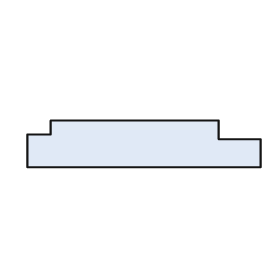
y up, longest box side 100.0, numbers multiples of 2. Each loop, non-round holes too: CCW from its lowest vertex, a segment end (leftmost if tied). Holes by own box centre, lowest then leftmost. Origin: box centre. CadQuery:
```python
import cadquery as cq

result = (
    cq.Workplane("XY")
    .moveTo(-50.0, -10.0)
    .lineTo(50.0, -10.0)
    .lineTo(50.0, 2.0)
    .lineTo(32.0, 2.0)
    .lineTo(32.0, 10.0)
    .lineTo(-40.0, 10.0)
    .lineTo(-40.0, 4.0)
    .lineTo(-50.0, 4.0)
    .close()
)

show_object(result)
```